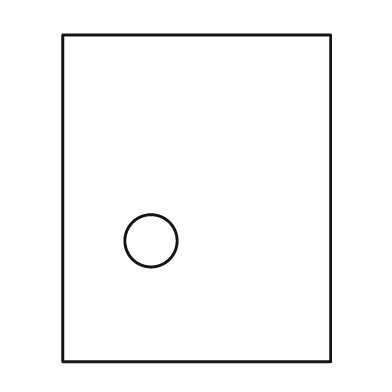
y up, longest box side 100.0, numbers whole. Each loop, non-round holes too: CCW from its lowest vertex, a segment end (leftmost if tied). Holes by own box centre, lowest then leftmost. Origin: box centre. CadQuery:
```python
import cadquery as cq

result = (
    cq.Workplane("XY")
    .moveTo(-41.0, -50.0)
    .lineTo(41.0, -50.0)
    .lineTo(41.0, 50.0)
    .lineTo(-41.0, 50.0)
    .close()
    .moveTo(-14.0, -13.0)
    .circle(8.0)
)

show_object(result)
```